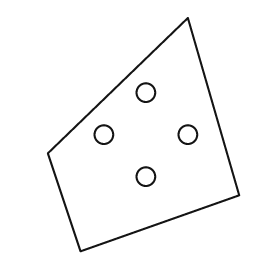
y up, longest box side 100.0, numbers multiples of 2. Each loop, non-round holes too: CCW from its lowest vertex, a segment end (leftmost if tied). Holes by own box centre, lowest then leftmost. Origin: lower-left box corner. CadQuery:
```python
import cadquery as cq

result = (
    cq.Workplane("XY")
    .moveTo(14.0, 0.0)
    .lineTo(82.0, 24.0)
    .lineTo(60.0, 100.0)
    .lineTo(0.0, 42.0)
    .close()
    .moveTo(42.0, 32.0)
    .circle(4.0)
    .moveTo(24.0, 50.0)
    .circle(4.0)
    .moveTo(60.0, 50.0)
    .circle(4.0)
    .moveTo(42.0, 68.0)
    .circle(4.0)
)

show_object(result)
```